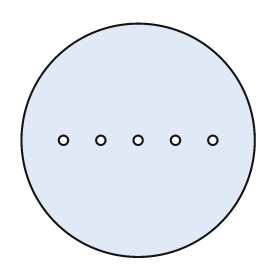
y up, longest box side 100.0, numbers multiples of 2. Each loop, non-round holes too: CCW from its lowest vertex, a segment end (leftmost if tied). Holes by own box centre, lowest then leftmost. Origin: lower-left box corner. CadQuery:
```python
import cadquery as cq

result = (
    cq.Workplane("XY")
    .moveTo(50.0, 50.0)
    .circle(50.0)
    .moveTo(18.0, 50.0)
    .circle(2.0)
    .moveTo(34.0, 50.0)
    .circle(2.0)
    .moveTo(50.0, 50.0)
    .circle(2.0)
    .moveTo(66.0, 50.0)
    .circle(2.0)
    .moveTo(82.0, 50.0)
    .circle(2.0)
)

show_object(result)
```